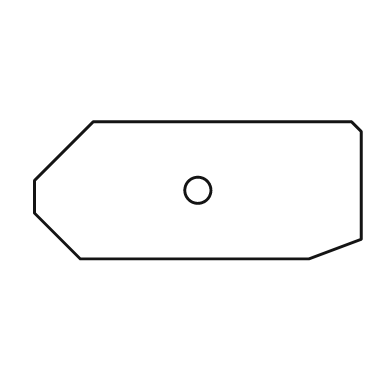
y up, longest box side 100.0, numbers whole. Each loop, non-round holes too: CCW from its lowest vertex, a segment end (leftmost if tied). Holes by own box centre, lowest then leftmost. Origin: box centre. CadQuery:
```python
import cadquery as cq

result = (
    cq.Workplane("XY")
    .moveTo(-36.0, -21.0)
    .lineTo(34.0, -21.0)
    .lineTo(50.0, -15.0)
    .lineTo(50.0, 18.0)
    .lineTo(47.0, 21.0)
    .lineTo(-32.0, 21.0)
    .lineTo(-50.0, 3.0)
    .lineTo(-50.0, -7.0)
    .close()
    .moveTo(0.0, 0.0)
    .circle(4.0)
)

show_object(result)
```